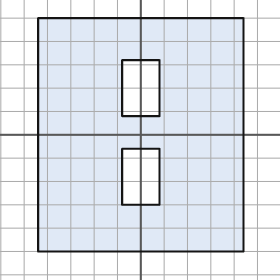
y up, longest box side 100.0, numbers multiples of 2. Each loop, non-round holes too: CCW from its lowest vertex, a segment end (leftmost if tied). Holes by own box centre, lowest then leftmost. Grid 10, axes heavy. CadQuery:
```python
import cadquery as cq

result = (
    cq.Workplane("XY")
    .moveTo(-44.0, -50.0)
    .lineTo(44.0, -50.0)
    .lineTo(44.0, 50.0)
    .lineTo(-44.0, 50.0)
    .close()
    .moveTo(-8.0, -30.0)
    .lineTo(8.0, -30.0)
    .lineTo(8.0, -6.0)
    .lineTo(-8.0, -6.0)
    .close()
    .moveTo(-8.0, 8.0)
    .lineTo(8.0, 8.0)
    .lineTo(8.0, 32.0)
    .lineTo(-8.0, 32.0)
    .close()
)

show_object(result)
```